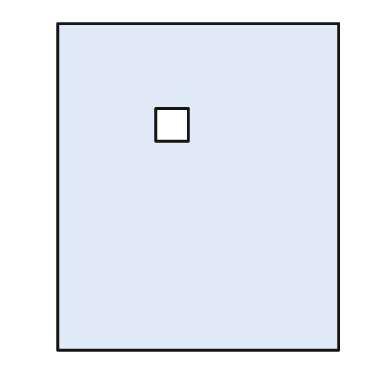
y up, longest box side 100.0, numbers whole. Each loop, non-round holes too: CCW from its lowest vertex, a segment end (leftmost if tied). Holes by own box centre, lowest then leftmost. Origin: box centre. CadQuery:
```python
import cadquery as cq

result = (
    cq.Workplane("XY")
    .moveTo(-43.0, -50.0)
    .lineTo(43.0, -50.0)
    .lineTo(43.0, 50.0)
    .lineTo(-43.0, 50.0)
    .close()
    .moveTo(-13.0, 14.0)
    .lineTo(-3.0, 14.0)
    .lineTo(-3.0, 24.0)
    .lineTo(-13.0, 24.0)
    .close()
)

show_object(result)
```